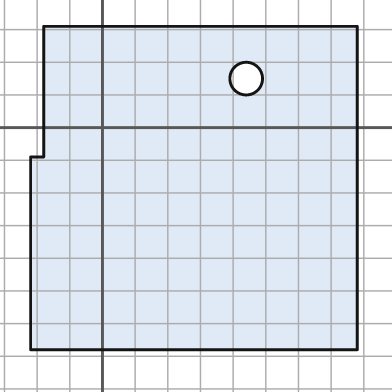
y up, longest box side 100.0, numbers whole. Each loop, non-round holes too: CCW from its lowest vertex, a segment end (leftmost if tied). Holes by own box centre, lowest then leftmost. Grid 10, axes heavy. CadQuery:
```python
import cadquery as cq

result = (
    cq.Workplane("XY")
    .moveTo(-22.0, -68.0)
    .lineTo(78.0, -68.0)
    .lineTo(78.0, 31.0)
    .lineTo(-18.0, 31.0)
    .lineTo(-18.0, -9.0)
    .lineTo(-22.0, -9.0)
    .close()
    .moveTo(44.0, 15.0)
    .circle(5.0)
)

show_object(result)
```